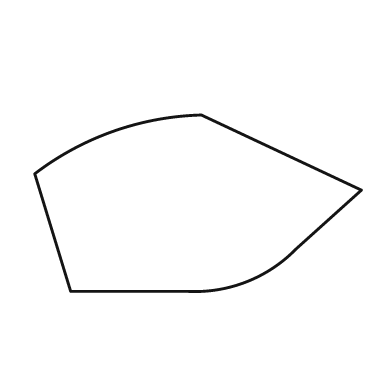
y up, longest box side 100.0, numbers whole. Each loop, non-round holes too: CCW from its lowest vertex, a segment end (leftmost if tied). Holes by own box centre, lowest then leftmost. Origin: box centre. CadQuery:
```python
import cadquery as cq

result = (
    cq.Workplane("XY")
    .moveTo(-39.0, -27.0)
    .lineTo(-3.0, -27.0)
    .threePointArc((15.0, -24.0), (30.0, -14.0))
    .lineTo(50.0, 4.0)
    .lineTo(1.0, 27.0)
    .threePointArc((-26.0, 22.0), (-50.0, 9.0))
    .close()
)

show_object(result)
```